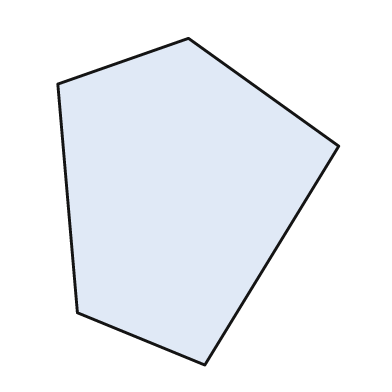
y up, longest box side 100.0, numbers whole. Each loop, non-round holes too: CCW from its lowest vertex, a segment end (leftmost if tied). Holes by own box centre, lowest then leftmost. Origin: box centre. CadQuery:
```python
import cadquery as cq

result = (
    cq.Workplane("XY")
    .moveTo(2.0, -50.0)
    .lineTo(43.0, 17.0)
    .lineTo(-3.0, 50.0)
    .lineTo(-43.0, 36.0)
    .lineTo(-37.0, -34.0)
    .close()
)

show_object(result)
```